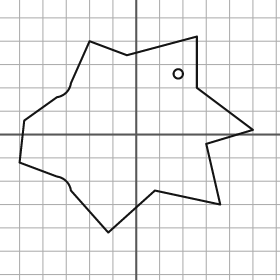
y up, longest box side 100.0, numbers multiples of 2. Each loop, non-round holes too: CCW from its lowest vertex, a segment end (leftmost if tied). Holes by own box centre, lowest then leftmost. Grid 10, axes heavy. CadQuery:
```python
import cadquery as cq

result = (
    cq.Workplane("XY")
    .moveTo(-12.0, -42.0)
    .lineTo(8.0, -24.0)
    .lineTo(36.0, -30.0)
    .lineTo(30.0, -4.0)
    .lineTo(50.0, 2.0)
    .lineTo(26.0, 20.0)
    .lineTo(26.0, 42.0)
    .lineTo(-4.0, 34.0)
    .lineTo(-20.0, 40.0)
    .lineTo(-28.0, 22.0)
    .threePointArc((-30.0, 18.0), (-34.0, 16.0))
    .lineTo(-48.0, 6.0)
    .lineTo(-50.0, -12.0)
    .lineTo(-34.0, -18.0)
    .threePointArc((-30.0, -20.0), (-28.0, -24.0))
    .close()
    .moveTo(18.0, 26.0)
    .circle(2.0)
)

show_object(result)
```